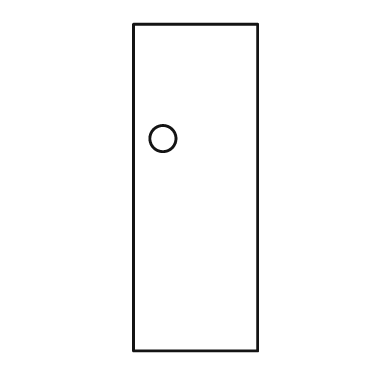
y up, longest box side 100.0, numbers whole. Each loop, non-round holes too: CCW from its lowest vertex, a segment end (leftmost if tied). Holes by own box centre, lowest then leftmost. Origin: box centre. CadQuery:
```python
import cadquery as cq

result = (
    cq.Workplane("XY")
    .moveTo(-19.0, -50.0)
    .lineTo(19.0, -50.0)
    .lineTo(19.0, 50.0)
    .lineTo(-19.0, 50.0)
    .close()
    .moveTo(-10.0, 15.0)
    .circle(4.0)
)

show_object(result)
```